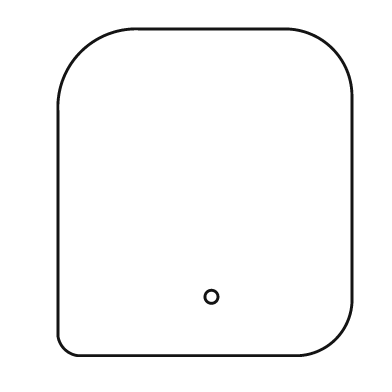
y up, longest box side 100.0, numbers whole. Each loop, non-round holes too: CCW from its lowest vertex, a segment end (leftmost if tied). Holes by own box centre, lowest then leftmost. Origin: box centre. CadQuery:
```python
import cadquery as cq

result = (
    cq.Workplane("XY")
    .moveTo(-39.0, -50.0)
    .lineTo(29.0, -50.0)
    .threePointArc((40.0, -45.0), (45.0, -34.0))
    .lineTo(45.0, 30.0)
    .threePointArc((39.0, 44.0), (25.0, 50.0))
    .lineTo(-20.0, 50.0)
    .threePointArc((-38.0, 43.0), (-45.0, 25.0))
    .lineTo(-45.0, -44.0)
    .threePointArc((-43.0, -48.0), (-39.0, -50.0))
    .close()
    .moveTo(2.0, -32.0)
    .circle(2.0)
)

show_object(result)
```